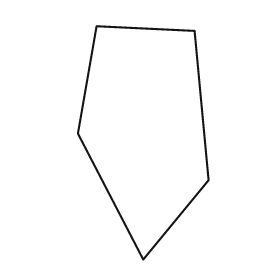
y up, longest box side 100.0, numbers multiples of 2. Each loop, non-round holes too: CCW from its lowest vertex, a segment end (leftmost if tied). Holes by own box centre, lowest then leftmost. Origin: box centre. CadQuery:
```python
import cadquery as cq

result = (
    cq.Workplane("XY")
    .moveTo(0.0, -50.0)
    .lineTo(28.0, -16.0)
    .lineTo(22.0, 48.0)
    .lineTo(-20.0, 50.0)
    .lineTo(-28.0, 4.0)
    .close()
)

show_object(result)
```